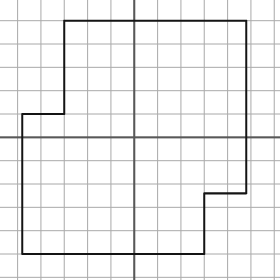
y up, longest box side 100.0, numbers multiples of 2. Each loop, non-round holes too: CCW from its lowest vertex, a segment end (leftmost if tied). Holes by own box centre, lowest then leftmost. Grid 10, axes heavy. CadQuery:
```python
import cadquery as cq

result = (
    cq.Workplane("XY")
    .moveTo(-48.0, -50.0)
    .lineTo(30.0, -50.0)
    .lineTo(30.0, -24.0)
    .lineTo(48.0, -24.0)
    .lineTo(48.0, 50.0)
    .lineTo(-30.0, 50.0)
    .lineTo(-30.0, 10.0)
    .lineTo(-48.0, 10.0)
    .close()
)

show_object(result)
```